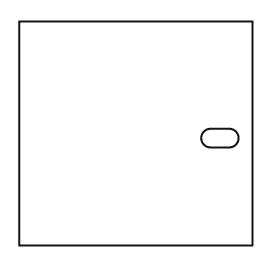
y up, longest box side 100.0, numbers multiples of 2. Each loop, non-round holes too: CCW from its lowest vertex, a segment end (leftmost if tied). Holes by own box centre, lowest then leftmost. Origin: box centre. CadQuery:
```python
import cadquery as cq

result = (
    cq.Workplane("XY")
    .moveTo(-50.0, -48.0)
    .lineTo(50.0, -48.0)
    .lineTo(50.0, 48.0)
    .lineTo(-50.0, 48.0)
    .close()
    .moveTo(32.0, -6.0)
    .lineTo(40.0, -6.0)
    .threePointArc((44.0, -2.0), (40.0, 2.0))
    .lineTo(32.0, 2.0)
    .threePointArc((28.0, -2.0), (32.0, -6.0))
    .close()
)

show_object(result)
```